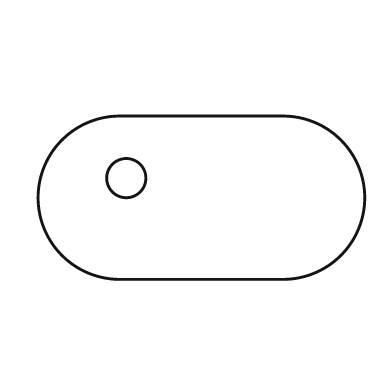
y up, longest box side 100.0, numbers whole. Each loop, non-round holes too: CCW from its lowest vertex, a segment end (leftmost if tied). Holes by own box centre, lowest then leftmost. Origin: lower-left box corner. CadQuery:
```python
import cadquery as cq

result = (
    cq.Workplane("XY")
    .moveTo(25.0, 0.0)
    .lineTo(75.0, 0.0)
    .threePointArc((100.0, 25.0), (75.0, 50.0))
    .lineTo(25.0, 50.0)
    .threePointArc((0.0, 25.0), (25.0, 0.0))
    .close()
    .moveTo(27.0, 31.0)
    .circle(6.0)
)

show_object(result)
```